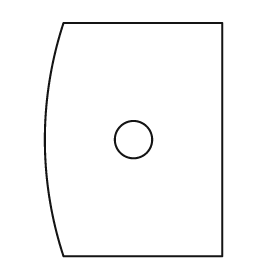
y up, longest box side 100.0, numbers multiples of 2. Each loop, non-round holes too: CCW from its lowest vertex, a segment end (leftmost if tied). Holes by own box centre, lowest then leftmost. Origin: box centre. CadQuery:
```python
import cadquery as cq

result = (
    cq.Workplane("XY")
    .moveTo(-30.0, -50.0)
    .lineTo(38.0, -50.0)
    .lineTo(38.0, 50.0)
    .lineTo(-30.0, 50.0)
    .threePointArc((-38.0, 0.0), (-30.0, -50.0))
    .close()
    .moveTo(0.0, 0.0)
    .circle(8.0)
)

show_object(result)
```